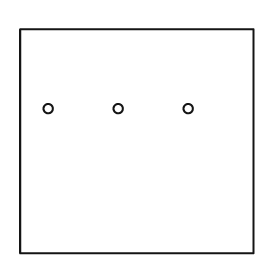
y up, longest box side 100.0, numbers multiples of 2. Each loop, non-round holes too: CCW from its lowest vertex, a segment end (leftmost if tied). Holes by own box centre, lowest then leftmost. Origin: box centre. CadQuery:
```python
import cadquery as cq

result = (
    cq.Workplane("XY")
    .moveTo(-50.0, -48.0)
    .lineTo(50.0, -48.0)
    .lineTo(50.0, 48.0)
    .lineTo(-50.0, 48.0)
    .close()
    .moveTo(-38.0, 14.0)
    .circle(2.0)
    .moveTo(-8.0, 14.0)
    .circle(2.0)
    .moveTo(22.0, 14.0)
    .circle(2.0)
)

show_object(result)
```